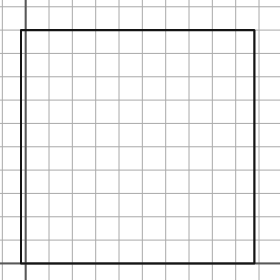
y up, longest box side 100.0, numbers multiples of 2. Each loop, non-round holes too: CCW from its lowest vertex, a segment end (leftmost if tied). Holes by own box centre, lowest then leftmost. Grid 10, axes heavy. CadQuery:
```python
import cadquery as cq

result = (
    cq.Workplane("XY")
    .moveTo(-2.0, 0.0)
    .lineTo(98.0, 0.0)
    .lineTo(98.0, 100.0)
    .lineTo(-2.0, 100.0)
    .close()
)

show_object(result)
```